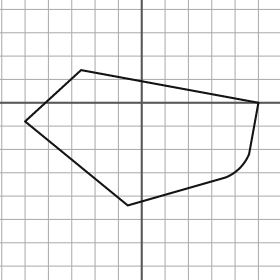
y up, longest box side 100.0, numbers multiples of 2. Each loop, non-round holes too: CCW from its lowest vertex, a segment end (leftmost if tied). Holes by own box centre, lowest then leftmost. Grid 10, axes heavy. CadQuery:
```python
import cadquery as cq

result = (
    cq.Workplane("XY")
    .moveTo(-6.0, -44.0)
    .lineTo(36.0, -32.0)
    .threePointArc((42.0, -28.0), (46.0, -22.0))
    .lineTo(50.0, 0.0)
    .lineTo(-26.0, 14.0)
    .lineTo(-50.0, -8.0)
    .close()
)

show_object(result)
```